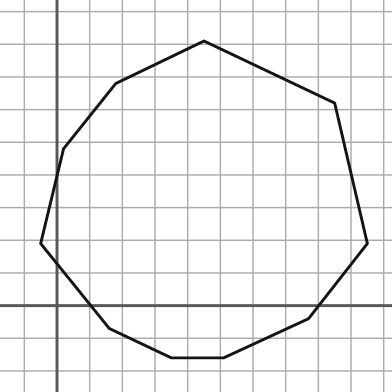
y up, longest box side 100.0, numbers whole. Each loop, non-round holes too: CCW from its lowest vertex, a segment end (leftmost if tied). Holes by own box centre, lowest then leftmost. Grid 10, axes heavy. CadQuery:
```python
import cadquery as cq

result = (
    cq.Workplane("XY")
    .moveTo(35.0, -16.0)
    .lineTo(51.0, -16.0)
    .lineTo(77.0, -4.0)
    .lineTo(95.0, 19.0)
    .lineTo(85.0, 62.0)
    .lineTo(45.0, 81.0)
    .lineTo(18.0, 68.0)
    .lineTo(2.0, 48.0)
    .lineTo(-5.0, 19.0)
    .lineTo(16.0, -7.0)
    .close()
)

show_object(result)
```